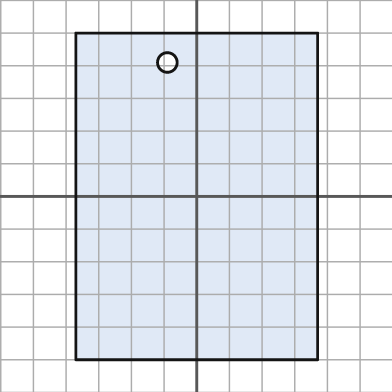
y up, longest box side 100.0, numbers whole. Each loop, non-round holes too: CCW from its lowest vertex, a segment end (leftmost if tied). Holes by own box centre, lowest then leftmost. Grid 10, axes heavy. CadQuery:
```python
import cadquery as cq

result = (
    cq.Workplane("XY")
    .moveTo(-37.0, -50.0)
    .lineTo(37.0, -50.0)
    .lineTo(37.0, 50.0)
    .lineTo(-37.0, 50.0)
    .close()
    .moveTo(-9.0, 41.0)
    .circle(3.0)
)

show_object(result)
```